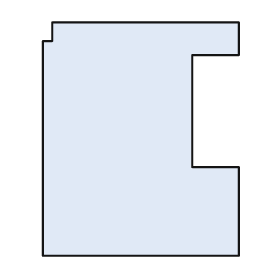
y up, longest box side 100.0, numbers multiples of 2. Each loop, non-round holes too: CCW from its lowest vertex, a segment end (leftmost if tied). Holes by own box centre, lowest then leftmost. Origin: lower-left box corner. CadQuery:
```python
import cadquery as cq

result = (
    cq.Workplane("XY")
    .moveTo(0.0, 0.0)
    .lineTo(84.0, 0.0)
    .lineTo(84.0, 38.0)
    .lineTo(64.0, 38.0)
    .lineTo(64.0, 86.0)
    .lineTo(84.0, 86.0)
    .lineTo(84.0, 100.0)
    .lineTo(4.0, 100.0)
    .lineTo(4.0, 92.0)
    .lineTo(0.0, 92.0)
    .close()
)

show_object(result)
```